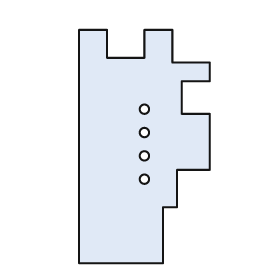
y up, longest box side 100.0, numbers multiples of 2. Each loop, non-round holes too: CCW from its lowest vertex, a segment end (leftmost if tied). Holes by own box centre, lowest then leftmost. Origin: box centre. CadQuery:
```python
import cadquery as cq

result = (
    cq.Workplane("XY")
    .moveTo(-28.0, -50.0)
    .lineTo(8.0, -50.0)
    .lineTo(8.0, -26.0)
    .lineTo(14.0, -26.0)
    .lineTo(14.0, -10.0)
    .lineTo(28.0, -10.0)
    .lineTo(28.0, 14.0)
    .lineTo(16.0, 14.0)
    .lineTo(16.0, 28.0)
    .lineTo(28.0, 28.0)
    .lineTo(28.0, 36.0)
    .lineTo(12.0, 36.0)
    .lineTo(12.0, 50.0)
    .lineTo(0.0, 50.0)
    .lineTo(0.0, 38.0)
    .lineTo(-16.0, 38.0)
    .lineTo(-16.0, 50.0)
    .lineTo(-28.0, 50.0)
    .close()
    .moveTo(0.0, -14.0)
    .circle(2.0)
    .moveTo(0.0, -4.0)
    .circle(2.0)
    .moveTo(0.0, 6.0)
    .circle(2.0)
    .moveTo(0.0, 16.0)
    .circle(2.0)
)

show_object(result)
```